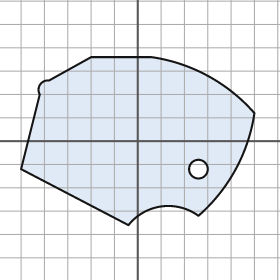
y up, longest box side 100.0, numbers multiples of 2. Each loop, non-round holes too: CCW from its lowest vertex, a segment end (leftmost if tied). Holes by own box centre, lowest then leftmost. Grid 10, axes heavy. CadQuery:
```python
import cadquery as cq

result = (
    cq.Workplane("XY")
    .moveTo(-4.0, -36.0)
    .threePointArc((10.0, -28.0), (26.0, -32.0))
    .threePointArc((42.0, -12.0), (50.0, 12.0))
    .threePointArc((30.0, 28.0), (6.0, 36.0))
    .lineTo(-20.0, 36.0)
    .lineTo(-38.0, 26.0)
    .threePointArc((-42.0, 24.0), (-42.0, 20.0))
    .lineTo(-50.0, -12.0)
    .close()
    .moveTo(26.0, -12.0)
    .circle(4.0)
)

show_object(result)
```